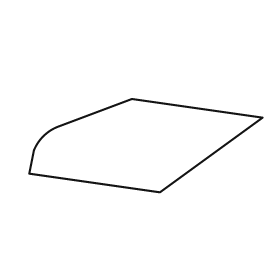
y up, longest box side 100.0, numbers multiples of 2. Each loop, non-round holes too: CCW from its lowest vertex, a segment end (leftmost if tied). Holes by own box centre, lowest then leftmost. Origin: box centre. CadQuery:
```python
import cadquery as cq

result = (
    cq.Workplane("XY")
    .moveTo(6.0, -20.0)
    .lineTo(50.0, 12.0)
    .lineTo(-6.0, 20.0)
    .lineTo(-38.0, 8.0)
    .threePointArc((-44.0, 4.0), (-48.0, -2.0))
    .lineTo(-50.0, -12.0)
    .close()
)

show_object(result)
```